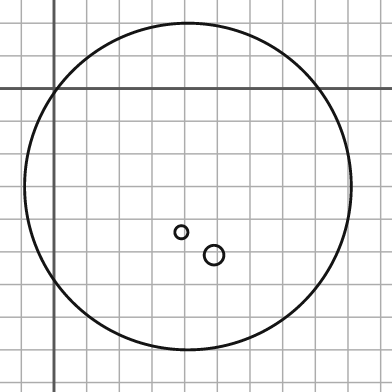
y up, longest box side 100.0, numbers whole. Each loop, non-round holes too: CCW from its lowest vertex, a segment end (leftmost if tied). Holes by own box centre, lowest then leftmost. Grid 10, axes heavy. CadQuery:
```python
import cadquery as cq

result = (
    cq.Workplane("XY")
    .moveTo(41.0, -30.0)
    .circle(50.0)
    .moveTo(49.0, -51.0)
    .circle(3.0)
    .moveTo(39.0, -44.0)
    .circle(2.0)
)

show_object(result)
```